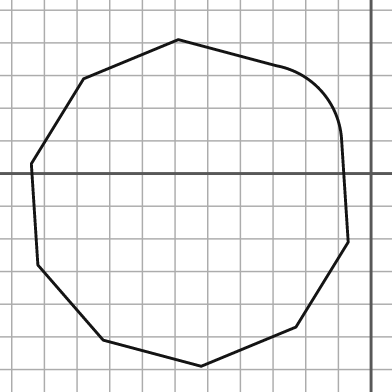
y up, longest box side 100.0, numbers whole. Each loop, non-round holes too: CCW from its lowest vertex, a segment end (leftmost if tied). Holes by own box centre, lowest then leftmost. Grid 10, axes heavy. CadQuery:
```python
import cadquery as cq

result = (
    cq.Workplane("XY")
    .moveTo(-52.0, -59.0)
    .lineTo(-23.0, -47.0)
    .lineTo(-7.0, -21.0)
    .lineTo(-9.0, 10.0)
    .threePointArc((-15.0, 25.0), (-29.0, 33.0))
    .lineTo(-59.0, 41.0)
    .lineTo(-88.0, 29.0)
    .lineTo(-104.0, 3.0)
    .lineTo(-102.0, -28.0)
    .lineTo(-82.0, -51.0)
    .close()
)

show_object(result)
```